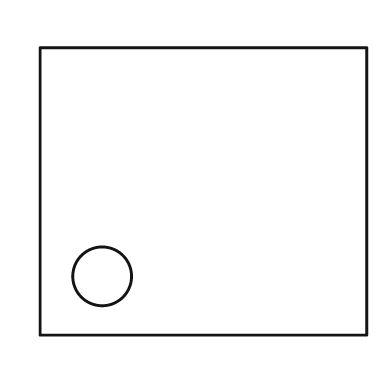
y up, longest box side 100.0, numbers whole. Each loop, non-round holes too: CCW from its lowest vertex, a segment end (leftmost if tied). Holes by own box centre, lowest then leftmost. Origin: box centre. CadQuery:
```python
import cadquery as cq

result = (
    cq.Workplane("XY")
    .moveTo(-50.0, -44.0)
    .lineTo(50.0, -44.0)
    .lineTo(50.0, 44.0)
    .lineTo(-50.0, 44.0)
    .close()
    .moveTo(-31.0, -26.0)
    .circle(9.0)
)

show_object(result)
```